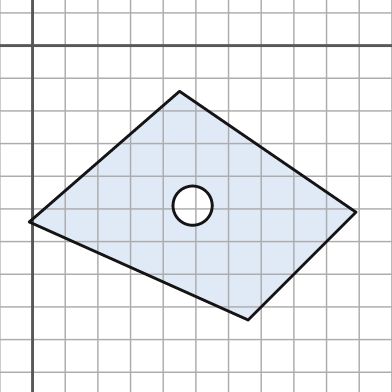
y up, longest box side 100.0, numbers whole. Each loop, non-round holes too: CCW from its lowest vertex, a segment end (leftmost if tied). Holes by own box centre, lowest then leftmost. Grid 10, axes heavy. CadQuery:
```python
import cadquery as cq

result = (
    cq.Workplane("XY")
    .moveTo(66.0, -84.0)
    .lineTo(99.0, -51.0)
    .lineTo(45.0, -14.0)
    .lineTo(-1.0, -54.0)
    .close()
    .moveTo(49.0, -49.0)
    .circle(6.0)
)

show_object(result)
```